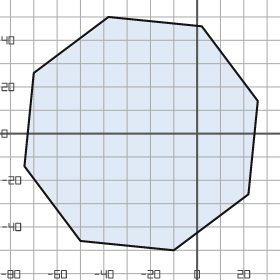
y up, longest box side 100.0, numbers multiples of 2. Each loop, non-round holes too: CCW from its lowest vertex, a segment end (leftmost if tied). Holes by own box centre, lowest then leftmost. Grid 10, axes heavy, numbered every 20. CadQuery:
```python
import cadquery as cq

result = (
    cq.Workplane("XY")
    .moveTo(-10.0, -50.0)
    .lineTo(22.0, -26.0)
    .lineTo(26.0, 14.0)
    .lineTo(2.0, 46.0)
    .lineTo(-38.0, 50.0)
    .lineTo(-70.0, 26.0)
    .lineTo(-74.0, -14.0)
    .lineTo(-50.0, -46.0)
    .close()
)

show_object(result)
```